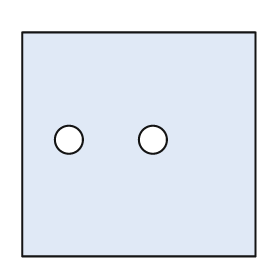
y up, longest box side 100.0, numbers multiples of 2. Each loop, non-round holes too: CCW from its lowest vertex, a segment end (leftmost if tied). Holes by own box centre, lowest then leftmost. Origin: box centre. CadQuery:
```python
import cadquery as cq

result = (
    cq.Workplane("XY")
    .moveTo(-50.0, -48.0)
    .lineTo(50.0, -48.0)
    .lineTo(50.0, 48.0)
    .lineTo(-50.0, 48.0)
    .close()
    .moveTo(-30.0, 2.0)
    .circle(6.0)
    .moveTo(6.0, 2.0)
    .circle(6.0)
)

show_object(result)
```